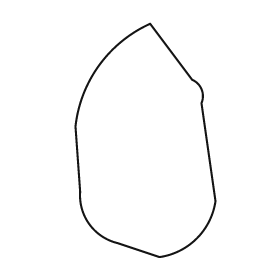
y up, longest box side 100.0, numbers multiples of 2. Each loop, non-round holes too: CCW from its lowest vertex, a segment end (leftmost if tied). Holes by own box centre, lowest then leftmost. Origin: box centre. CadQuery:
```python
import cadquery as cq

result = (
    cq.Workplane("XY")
    .moveTo(6.0, -50.0)
    .threePointArc((22.0, -42.0), (30.0, -26.0))
    .lineTo(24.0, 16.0)
    .threePointArc((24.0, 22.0), (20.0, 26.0))
    .lineTo(2.0, 50.0)
    .threePointArc((-20.0, 32.0), (-30.0, 6.0))
    .lineTo(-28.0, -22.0)
    .threePointArc((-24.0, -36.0), (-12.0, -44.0))
    .close()
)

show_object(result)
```